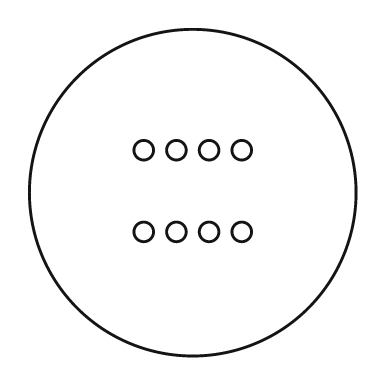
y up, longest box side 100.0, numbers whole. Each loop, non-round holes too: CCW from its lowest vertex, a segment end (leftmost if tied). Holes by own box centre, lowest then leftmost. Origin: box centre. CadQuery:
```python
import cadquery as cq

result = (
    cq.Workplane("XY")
    .moveTo(0.0, 0.0)
    .circle(50.0)
    .moveTo(-15.0, -12.0)
    .circle(3.0)
    .moveTo(-5.0, -12.0)
    .circle(3.0)
    .moveTo(5.0, -12.0)
    .circle(3.0)
    .moveTo(15.0, -12.0)
    .circle(3.0)
    .moveTo(-15.0, 13.0)
    .circle(3.0)
    .moveTo(-5.0, 13.0)
    .circle(3.0)
    .moveTo(5.0, 13.0)
    .circle(3.0)
    .moveTo(15.0, 13.0)
    .circle(3.0)
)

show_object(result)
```